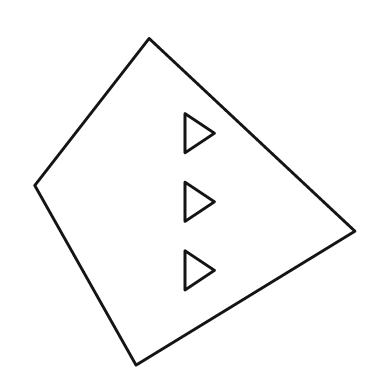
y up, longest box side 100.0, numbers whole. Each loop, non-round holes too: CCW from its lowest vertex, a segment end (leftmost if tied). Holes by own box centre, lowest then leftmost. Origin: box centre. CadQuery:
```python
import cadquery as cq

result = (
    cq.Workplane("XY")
    .moveTo(-18.0, -50.0)
    .lineTo(49.0, -9.0)
    .lineTo(-14.0, 50.0)
    .lineTo(-49.0, 5.0)
    .close()
    .moveTo(-3.0, -27.0)
    .lineTo(6.0, -21.0)
    .lineTo(-3.0, -15.0)
    .close()
    .moveTo(-3.0, -6.0)
    .lineTo(6.0, 0.0)
    .lineTo(-3.0, 6.0)
    .close()
    .moveTo(-3.0, 15.0)
    .lineTo(6.0, 21.0)
    .lineTo(-3.0, 27.0)
    .close()
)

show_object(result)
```